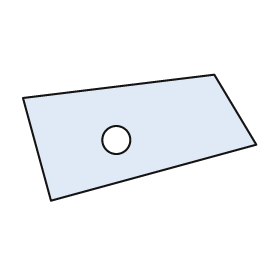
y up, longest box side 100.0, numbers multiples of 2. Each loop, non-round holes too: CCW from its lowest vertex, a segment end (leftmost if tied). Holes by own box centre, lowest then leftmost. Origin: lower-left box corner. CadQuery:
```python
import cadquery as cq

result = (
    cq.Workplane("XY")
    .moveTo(12.0, 0.0)
    .lineTo(100.0, 24.0)
    .lineTo(82.0, 54.0)
    .lineTo(0.0, 44.0)
    .close()
    .moveTo(40.0, 26.0)
    .circle(6.0)
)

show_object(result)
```